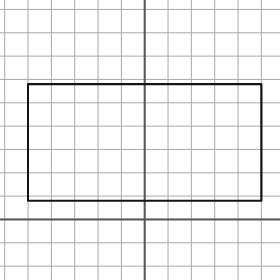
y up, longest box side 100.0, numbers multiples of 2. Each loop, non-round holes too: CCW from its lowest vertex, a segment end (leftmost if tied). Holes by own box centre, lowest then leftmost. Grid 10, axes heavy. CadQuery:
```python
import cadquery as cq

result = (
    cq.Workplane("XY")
    .moveTo(-50.0, 8.0)
    .lineTo(50.0, 8.0)
    .lineTo(50.0, 58.0)
    .lineTo(-50.0, 58.0)
    .close()
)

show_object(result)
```